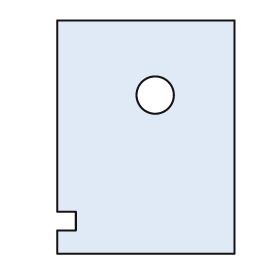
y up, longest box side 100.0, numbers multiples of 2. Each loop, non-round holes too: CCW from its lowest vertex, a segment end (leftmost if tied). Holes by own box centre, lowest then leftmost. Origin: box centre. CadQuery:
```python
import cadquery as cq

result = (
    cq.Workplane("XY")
    .moveTo(-38.0, -50.0)
    .lineTo(38.0, -50.0)
    .lineTo(38.0, 50.0)
    .lineTo(-38.0, 50.0)
    .lineTo(-38.0, -32.0)
    .lineTo(-30.0, -32.0)
    .lineTo(-30.0, -40.0)
    .lineTo(-38.0, -40.0)
    .close()
    .moveTo(4.0, 18.0)
    .circle(8.0)
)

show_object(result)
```